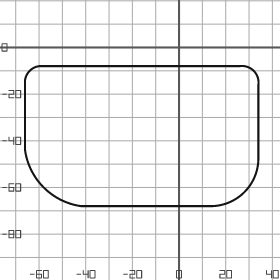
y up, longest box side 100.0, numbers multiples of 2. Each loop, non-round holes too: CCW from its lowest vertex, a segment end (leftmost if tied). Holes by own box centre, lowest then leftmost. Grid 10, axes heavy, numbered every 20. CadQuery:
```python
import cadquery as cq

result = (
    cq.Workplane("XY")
    .moveTo(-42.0, -68.0)
    .lineTo(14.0, -68.0)
    .threePointArc((28.0, -62.0), (34.0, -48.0))
    .lineTo(34.0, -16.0)
    .threePointArc((32.0, -10.0), (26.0, -8.0))
    .lineTo(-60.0, -8.0)
    .threePointArc((-64.0, -10.0), (-66.0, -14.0))
    .lineTo(-66.0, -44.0)
    .threePointArc((-58.0, -60.0), (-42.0, -68.0))
    .close()
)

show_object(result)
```